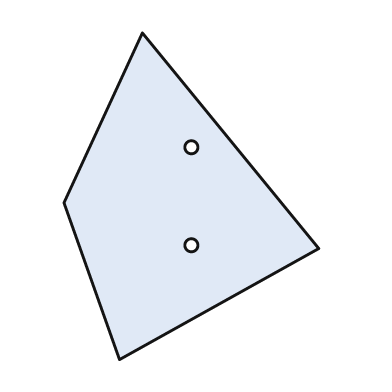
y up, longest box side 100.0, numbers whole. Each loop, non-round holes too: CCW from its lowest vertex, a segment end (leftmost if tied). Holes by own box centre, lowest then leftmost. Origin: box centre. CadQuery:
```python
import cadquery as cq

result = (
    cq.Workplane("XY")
    .moveTo(-22.0, -50.0)
    .lineTo(39.0, -16.0)
    .lineTo(-15.0, 50.0)
    .lineTo(-39.0, -2.0)
    .close()
    .moveTo(0.0, -15.0)
    .circle(2.0)
    .moveTo(0.0, 15.0)
    .circle(2.0)
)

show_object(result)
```